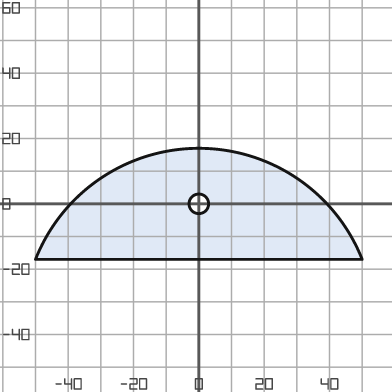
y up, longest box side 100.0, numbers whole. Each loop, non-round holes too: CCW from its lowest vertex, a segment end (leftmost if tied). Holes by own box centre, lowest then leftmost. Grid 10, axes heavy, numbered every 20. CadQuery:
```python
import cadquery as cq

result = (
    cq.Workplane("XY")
    .moveTo(-50.0, -17.0)
    .lineTo(50.0, -17.0)
    .threePointArc((0.0, 17.0), (-50.0, -17.0))
    .close()
    .moveTo(0.0, 0.0)
    .circle(3.0)
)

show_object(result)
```